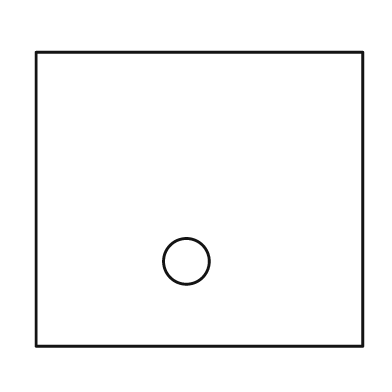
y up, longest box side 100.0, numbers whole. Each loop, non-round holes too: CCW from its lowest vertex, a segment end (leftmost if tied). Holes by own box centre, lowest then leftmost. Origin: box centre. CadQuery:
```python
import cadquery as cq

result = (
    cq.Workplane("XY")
    .moveTo(-50.0, -45.0)
    .lineTo(50.0, -45.0)
    .lineTo(50.0, 45.0)
    .lineTo(-50.0, 45.0)
    .close()
    .moveTo(-4.0, -19.0)
    .circle(7.0)
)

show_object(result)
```